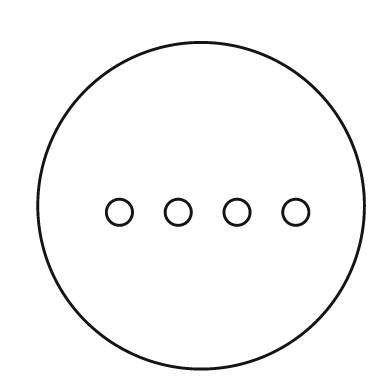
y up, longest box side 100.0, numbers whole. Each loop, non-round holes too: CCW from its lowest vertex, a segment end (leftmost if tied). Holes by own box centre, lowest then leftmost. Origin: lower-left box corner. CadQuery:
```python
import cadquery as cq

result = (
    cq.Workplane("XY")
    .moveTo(50.0, 50.0)
    .circle(50.0)
    .moveTo(25.0, 48.0)
    .circle(4.0)
    .moveTo(43.0, 48.0)
    .circle(4.0)
    .moveTo(61.0, 48.0)
    .circle(4.0)
    .moveTo(79.0, 48.0)
    .circle(4.0)
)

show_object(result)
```